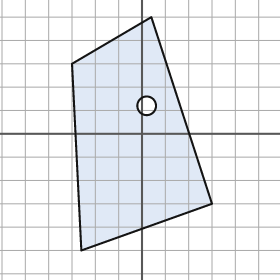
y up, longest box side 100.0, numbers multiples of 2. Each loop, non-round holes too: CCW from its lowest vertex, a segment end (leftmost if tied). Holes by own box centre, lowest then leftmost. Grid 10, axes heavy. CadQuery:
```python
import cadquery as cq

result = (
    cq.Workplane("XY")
    .moveTo(-26.0, -50.0)
    .lineTo(30.0, -30.0)
    .lineTo(4.0, 50.0)
    .lineTo(-30.0, 30.0)
    .close()
    .moveTo(2.0, 12.0)
    .circle(4.0)
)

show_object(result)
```